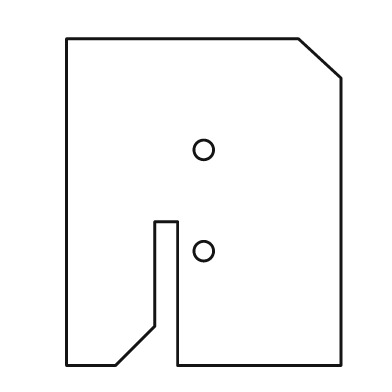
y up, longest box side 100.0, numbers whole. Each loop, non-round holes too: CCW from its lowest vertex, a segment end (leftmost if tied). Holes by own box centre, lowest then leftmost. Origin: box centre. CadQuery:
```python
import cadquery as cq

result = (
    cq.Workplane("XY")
    .moveTo(-42.0, -50.0)
    .lineTo(-27.0, -50.0)
    .lineTo(-15.0, -38.0)
    .lineTo(-15.0, -6.0)
    .lineTo(-8.0, -6.0)
    .lineTo(-8.0, -50.0)
    .lineTo(42.0, -50.0)
    .lineTo(42.0, 38.0)
    .lineTo(29.0, 50.0)
    .lineTo(-42.0, 50.0)
    .close()
    .moveTo(0.0, -15.0)
    .circle(3.0)
    .moveTo(0.0, 16.0)
    .circle(3.0)
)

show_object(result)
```